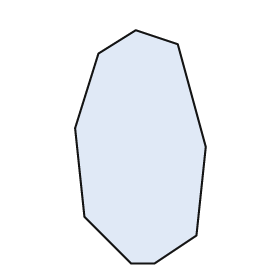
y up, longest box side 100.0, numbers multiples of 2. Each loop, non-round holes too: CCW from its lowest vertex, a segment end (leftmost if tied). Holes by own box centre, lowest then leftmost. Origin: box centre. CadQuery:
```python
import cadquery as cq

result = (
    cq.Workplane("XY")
    .moveTo(-4.0, -50.0)
    .lineTo(6.0, -50.0)
    .lineTo(24.0, -38.0)
    .lineTo(28.0, 0.0)
    .lineTo(16.0, 44.0)
    .lineTo(-2.0, 50.0)
    .lineTo(-18.0, 40.0)
    .lineTo(-28.0, 8.0)
    .lineTo(-24.0, -30.0)
    .close()
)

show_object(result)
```